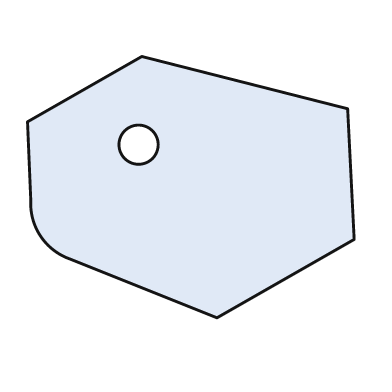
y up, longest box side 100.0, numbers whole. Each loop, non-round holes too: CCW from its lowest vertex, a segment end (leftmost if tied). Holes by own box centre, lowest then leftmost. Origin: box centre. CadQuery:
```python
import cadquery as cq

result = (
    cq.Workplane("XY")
    .moveTo(8.0, -40.0)
    .lineTo(50.0, -16.0)
    .lineTo(48.0, 24.0)
    .lineTo(-15.0, 40.0)
    .lineTo(-50.0, 20.0)
    .lineTo(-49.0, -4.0)
    .threePointArc((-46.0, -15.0), (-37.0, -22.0))
    .close()
    .moveTo(-16.0, 13.0)
    .circle(6.0)
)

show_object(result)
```